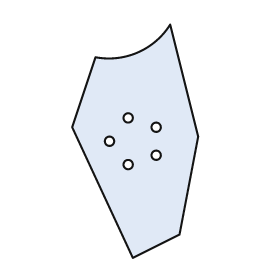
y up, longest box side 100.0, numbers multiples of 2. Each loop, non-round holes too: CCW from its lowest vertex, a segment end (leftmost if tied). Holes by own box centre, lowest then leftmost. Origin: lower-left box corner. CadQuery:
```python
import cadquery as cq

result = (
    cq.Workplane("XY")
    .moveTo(26.0, 0.0)
    .lineTo(46.0, 10.0)
    .lineTo(54.0, 52.0)
    .lineTo(42.0, 100.0)
    .threePointArc((28.0, 88.0), (10.0, 86.0))
    .lineTo(0.0, 56.0)
    .close()
    .moveTo(24.0, 40.0)
    .circle(2.0)
    .moveTo(36.0, 44.0)
    .circle(2.0)
    .moveTo(16.0, 50.0)
    .circle(2.0)
    .moveTo(36.0, 56.0)
    .circle(2.0)
    .moveTo(24.0, 60.0)
    .circle(2.0)
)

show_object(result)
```